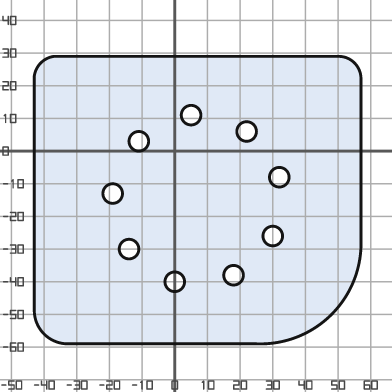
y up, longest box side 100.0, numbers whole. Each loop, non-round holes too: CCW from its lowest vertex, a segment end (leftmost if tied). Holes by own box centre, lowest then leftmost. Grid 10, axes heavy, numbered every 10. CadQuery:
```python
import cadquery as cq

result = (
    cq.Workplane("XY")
    .moveTo(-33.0, -59.0)
    .lineTo(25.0, -59.0)
    .threePointArc((48.0, -50.0), (57.0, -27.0))
    .lineTo(57.0, 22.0)
    .threePointArc((55.0, 27.0), (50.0, 29.0))
    .lineTo(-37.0, 29.0)
    .threePointArc((-41.0, 27.0), (-43.0, 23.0))
    .lineTo(-43.0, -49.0)
    .threePointArc((-40.0, -56.0), (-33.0, -59.0))
    .close()
    .moveTo(0.0, -40.0)
    .circle(3.0)
    .moveTo(18.0, -38.0)
    .circle(3.0)
    .moveTo(-14.0, -30.0)
    .circle(3.0)
    .moveTo(30.0, -26.0)
    .circle(3.0)
    .moveTo(-19.0, -13.0)
    .circle(3.0)
    .moveTo(32.0, -8.0)
    .circle(3.0)
    .moveTo(-11.0, 3.0)
    .circle(3.0)
    .moveTo(22.0, 6.0)
    .circle(3.0)
    .moveTo(5.0, 11.0)
    .circle(3.0)
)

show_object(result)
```